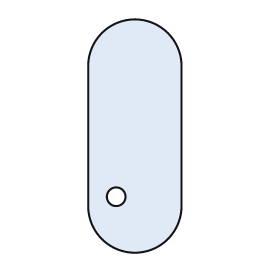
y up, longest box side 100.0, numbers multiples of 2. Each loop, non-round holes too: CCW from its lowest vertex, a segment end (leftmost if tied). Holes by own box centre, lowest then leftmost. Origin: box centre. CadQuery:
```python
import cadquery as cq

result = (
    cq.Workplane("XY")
    .moveTo(-20.0, -30.0)
    .threePointArc((0.0, -50.0), (20.0, -30.0))
    .lineTo(20.0, 30.0)
    .threePointArc((0.0, 50.0), (-20.0, 30.0))
    .close()
    .moveTo(-8.0, -26.0)
    .circle(4.0)
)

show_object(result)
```